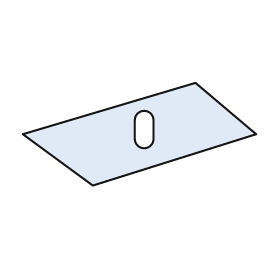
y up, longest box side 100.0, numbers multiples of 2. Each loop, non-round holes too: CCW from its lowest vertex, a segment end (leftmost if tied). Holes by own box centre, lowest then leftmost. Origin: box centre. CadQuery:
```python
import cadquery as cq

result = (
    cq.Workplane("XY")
    .moveTo(-20.0, -22.0)
    .lineTo(50.0, 0.0)
    .lineTo(24.0, 22.0)
    .lineTo(-50.0, 0.0)
    .close()
    .moveTo(-2.0, -2.0)
    .threePointArc((2.0, -6.0), (6.0, -2.0))
    .lineTo(6.0, 6.0)
    .threePointArc((2.0, 10.0), (-2.0, 6.0))
    .close()
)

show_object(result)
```